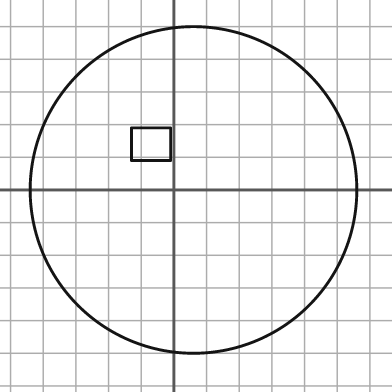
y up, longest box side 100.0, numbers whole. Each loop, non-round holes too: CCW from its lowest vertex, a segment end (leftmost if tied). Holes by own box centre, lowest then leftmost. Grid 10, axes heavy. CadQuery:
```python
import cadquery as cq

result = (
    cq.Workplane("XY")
    .moveTo(6.0, 0.0)
    .circle(50.0)
    .moveTo(-13.0, 9.0)
    .lineTo(-1.0, 9.0)
    .lineTo(-1.0, 19.0)
    .lineTo(-13.0, 19.0)
    .close()
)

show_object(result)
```